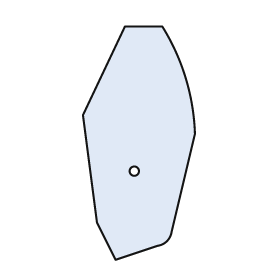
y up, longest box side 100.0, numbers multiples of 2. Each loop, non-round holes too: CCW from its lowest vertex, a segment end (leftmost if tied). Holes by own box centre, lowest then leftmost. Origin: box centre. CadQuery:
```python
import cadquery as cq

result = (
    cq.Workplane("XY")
    .moveTo(-10.0, -50.0)
    .lineTo(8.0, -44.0)
    .threePointArc((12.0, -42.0), (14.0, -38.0))
    .lineTo(24.0, 4.0)
    .threePointArc((20.0, 28.0), (10.0, 50.0))
    .lineTo(-6.0, 50.0)
    .lineTo(-24.0, 12.0)
    .lineTo(-18.0, -34.0)
    .close()
    .moveTo(-2.0, -12.0)
    .circle(2.0)
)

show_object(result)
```